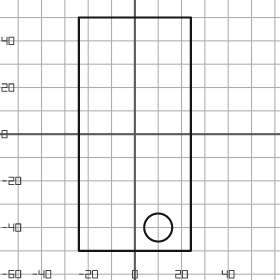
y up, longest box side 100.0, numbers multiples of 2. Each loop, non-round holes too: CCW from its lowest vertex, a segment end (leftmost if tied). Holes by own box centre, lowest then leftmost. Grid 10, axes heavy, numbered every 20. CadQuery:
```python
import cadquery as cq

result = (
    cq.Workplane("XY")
    .moveTo(-24.0, -50.0)
    .lineTo(24.0, -50.0)
    .lineTo(24.0, 50.0)
    .lineTo(-24.0, 50.0)
    .close()
    .moveTo(10.0, -40.0)
    .circle(6.0)
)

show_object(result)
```